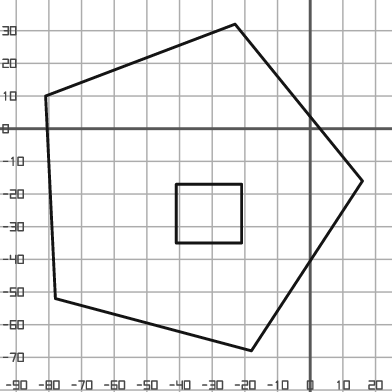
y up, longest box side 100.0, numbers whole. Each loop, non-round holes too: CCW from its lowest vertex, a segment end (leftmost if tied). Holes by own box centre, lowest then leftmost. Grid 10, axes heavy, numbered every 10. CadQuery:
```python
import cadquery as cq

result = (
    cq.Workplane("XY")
    .moveTo(-18.0, -68.0)
    .lineTo(16.0, -16.0)
    .lineTo(-23.0, 32.0)
    .lineTo(-81.0, 10.0)
    .lineTo(-78.0, -52.0)
    .close()
    .moveTo(-41.0, -35.0)
    .lineTo(-21.0, -35.0)
    .lineTo(-21.0, -17.0)
    .lineTo(-41.0, -17.0)
    .close()
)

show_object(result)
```